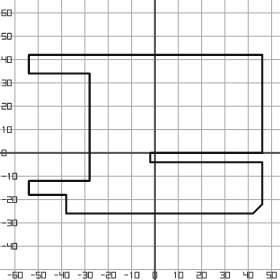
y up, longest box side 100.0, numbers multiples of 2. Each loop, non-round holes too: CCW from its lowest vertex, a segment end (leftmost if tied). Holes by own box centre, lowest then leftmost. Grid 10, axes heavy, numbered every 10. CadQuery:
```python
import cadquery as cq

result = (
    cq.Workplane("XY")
    .moveTo(-38.0, -26.0)
    .lineTo(42.0, -26.0)
    .lineTo(46.0, -22.0)
    .lineTo(46.0, -4.0)
    .lineTo(-2.0, -4.0)
    .lineTo(-2.0, 0.0)
    .lineTo(46.0, 0.0)
    .lineTo(46.0, 42.0)
    .lineTo(-54.0, 42.0)
    .lineTo(-54.0, 34.0)
    .lineTo(-28.0, 34.0)
    .lineTo(-28.0, -12.0)
    .lineTo(-54.0, -12.0)
    .lineTo(-54.0, -18.0)
    .lineTo(-38.0, -18.0)
    .close()
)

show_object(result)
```